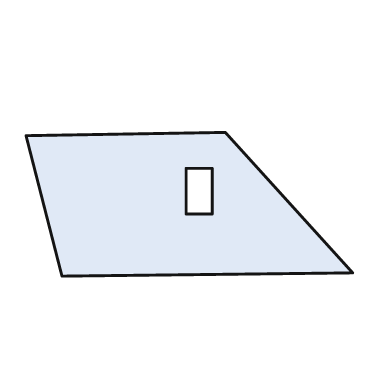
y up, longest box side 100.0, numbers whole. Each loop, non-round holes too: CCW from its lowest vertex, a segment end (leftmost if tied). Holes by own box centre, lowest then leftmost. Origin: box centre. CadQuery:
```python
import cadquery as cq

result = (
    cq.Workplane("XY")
    .moveTo(-39.0, -22.0)
    .lineTo(50.0, -21.0)
    .lineTo(11.0, 22.0)
    .lineTo(-50.0, 21.0)
    .close()
    .moveTo(-1.0, -3.0)
    .lineTo(7.0, -3.0)
    .lineTo(7.0, 11.0)
    .lineTo(-1.0, 11.0)
    .close()
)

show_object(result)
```